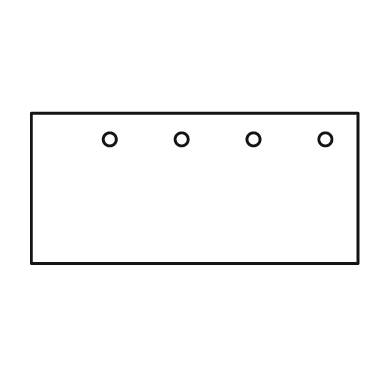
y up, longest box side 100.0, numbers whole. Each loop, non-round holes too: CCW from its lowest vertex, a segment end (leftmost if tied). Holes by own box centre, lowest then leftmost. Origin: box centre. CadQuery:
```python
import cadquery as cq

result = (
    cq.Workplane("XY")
    .moveTo(-50.0, -23.0)
    .lineTo(50.0, -23.0)
    .lineTo(50.0, 23.0)
    .lineTo(-50.0, 23.0)
    .close()
    .moveTo(-26.0, 15.0)
    .circle(2.0)
    .moveTo(-4.0, 15.0)
    .circle(2.0)
    .moveTo(18.0, 15.0)
    .circle(2.0)
    .moveTo(40.0, 15.0)
    .circle(2.0)
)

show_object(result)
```